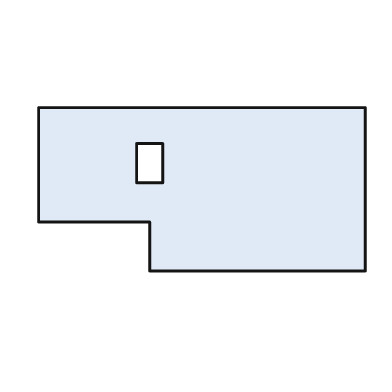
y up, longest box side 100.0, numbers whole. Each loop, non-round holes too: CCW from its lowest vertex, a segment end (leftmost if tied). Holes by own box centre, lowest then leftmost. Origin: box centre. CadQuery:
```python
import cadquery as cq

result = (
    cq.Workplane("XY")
    .moveTo(-16.0, -25.0)
    .lineTo(50.0, -25.0)
    .lineTo(50.0, 25.0)
    .lineTo(-50.0, 25.0)
    .lineTo(-50.0, -10.0)
    .lineTo(-16.0, -10.0)
    .close()
    .moveTo(-20.0, 2.0)
    .lineTo(-12.0, 2.0)
    .lineTo(-12.0, 14.0)
    .lineTo(-20.0, 14.0)
    .close()
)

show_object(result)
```